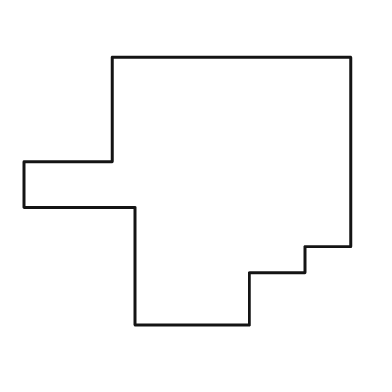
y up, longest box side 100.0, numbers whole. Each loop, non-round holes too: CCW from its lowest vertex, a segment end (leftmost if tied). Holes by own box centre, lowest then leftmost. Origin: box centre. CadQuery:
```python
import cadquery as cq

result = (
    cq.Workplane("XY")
    .moveTo(-16.0, -41.0)
    .lineTo(19.0, -41.0)
    .lineTo(19.0, -25.0)
    .lineTo(36.0, -25.0)
    .lineTo(36.0, -17.0)
    .lineTo(50.0, -17.0)
    .lineTo(50.0, 41.0)
    .lineTo(-23.0, 41.0)
    .lineTo(-23.0, 9.0)
    .lineTo(-50.0, 9.0)
    .lineTo(-50.0, -5.0)
    .lineTo(-16.0, -5.0)
    .close()
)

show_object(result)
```